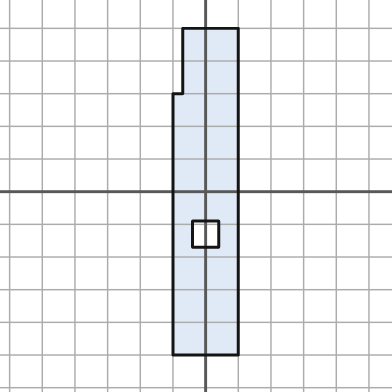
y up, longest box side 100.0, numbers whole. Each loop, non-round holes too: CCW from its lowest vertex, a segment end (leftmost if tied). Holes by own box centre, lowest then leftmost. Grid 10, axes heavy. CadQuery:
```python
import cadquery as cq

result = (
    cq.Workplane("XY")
    .moveTo(-10.0, -50.0)
    .lineTo(10.0, -50.0)
    .lineTo(10.0, 50.0)
    .lineTo(-7.0, 50.0)
    .lineTo(-7.0, 30.0)
    .lineTo(-10.0, 30.0)
    .close()
    .moveTo(-4.0, -17.0)
    .lineTo(4.0, -17.0)
    .lineTo(4.0, -9.0)
    .lineTo(-4.0, -9.0)
    .close()
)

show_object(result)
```